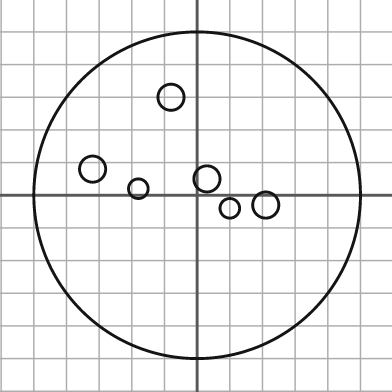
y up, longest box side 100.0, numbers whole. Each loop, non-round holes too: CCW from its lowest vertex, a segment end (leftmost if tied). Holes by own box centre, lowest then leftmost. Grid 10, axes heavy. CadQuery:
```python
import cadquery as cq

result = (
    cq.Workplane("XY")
    .moveTo(0.0, 0.0)
    .circle(50.0)
    .moveTo(10.0, -4.0)
    .circle(3.0)
    .moveTo(21.0, -3.0)
    .circle(4.0)
    .moveTo(-18.0, 2.0)
    .circle(3.0)
    .moveTo(3.0, 5.0)
    .circle(4.0)
    .moveTo(-32.0, 8.0)
    .circle(4.0)
    .moveTo(-8.0, 30.0)
    .circle(4.0)
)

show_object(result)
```